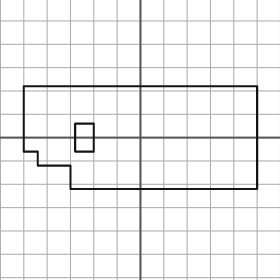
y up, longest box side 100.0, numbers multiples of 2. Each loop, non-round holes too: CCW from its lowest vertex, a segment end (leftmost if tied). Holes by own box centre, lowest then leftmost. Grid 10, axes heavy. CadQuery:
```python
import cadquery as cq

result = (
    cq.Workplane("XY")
    .moveTo(-30.0, -22.0)
    .lineTo(50.0, -22.0)
    .lineTo(50.0, 22.0)
    .lineTo(-50.0, 22.0)
    .lineTo(-50.0, -6.0)
    .lineTo(-44.0, -6.0)
    .lineTo(-44.0, -12.0)
    .lineTo(-30.0, -12.0)
    .close()
    .moveTo(-28.0, -6.0)
    .lineTo(-20.0, -6.0)
    .lineTo(-20.0, 6.0)
    .lineTo(-28.0, 6.0)
    .close()
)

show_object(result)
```